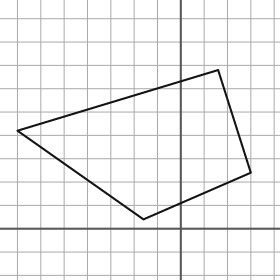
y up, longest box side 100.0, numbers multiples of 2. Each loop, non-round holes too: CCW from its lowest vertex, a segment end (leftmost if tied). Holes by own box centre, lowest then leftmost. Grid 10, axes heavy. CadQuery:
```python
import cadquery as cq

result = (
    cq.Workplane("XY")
    .moveTo(-16.0, 4.0)
    .lineTo(30.0, 24.0)
    .lineTo(16.0, 68.0)
    .lineTo(-70.0, 42.0)
    .close()
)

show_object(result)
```